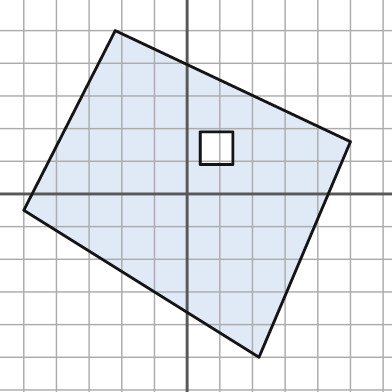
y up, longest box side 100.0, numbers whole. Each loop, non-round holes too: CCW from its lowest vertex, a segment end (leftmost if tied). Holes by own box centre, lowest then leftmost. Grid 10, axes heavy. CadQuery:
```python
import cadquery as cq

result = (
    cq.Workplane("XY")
    .moveTo(22.0, -50.0)
    .lineTo(50.0, 16.0)
    .lineTo(-22.0, 50.0)
    .lineTo(-50.0, -5.0)
    .close()
    .moveTo(4.0, 9.0)
    .lineTo(14.0, 9.0)
    .lineTo(14.0, 19.0)
    .lineTo(4.0, 19.0)
    .close()
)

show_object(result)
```